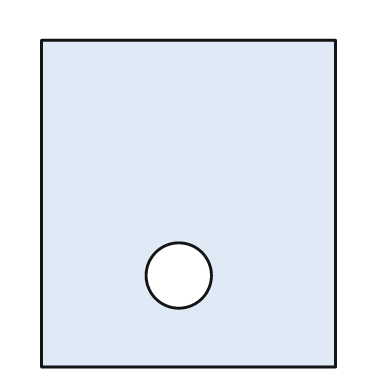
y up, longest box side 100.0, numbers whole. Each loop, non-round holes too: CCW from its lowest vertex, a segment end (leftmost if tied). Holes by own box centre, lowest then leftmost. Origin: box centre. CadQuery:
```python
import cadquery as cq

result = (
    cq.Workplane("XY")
    .moveTo(-45.0, -50.0)
    .lineTo(45.0, -50.0)
    .lineTo(45.0, 50.0)
    .lineTo(-45.0, 50.0)
    .close()
    .moveTo(-3.0, -22.0)
    .circle(10.0)
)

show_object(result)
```